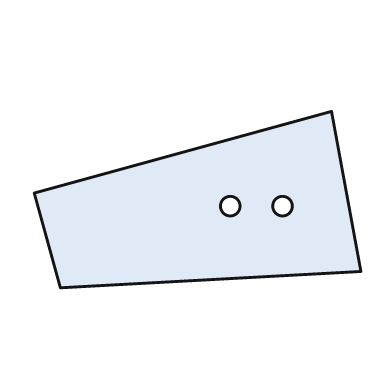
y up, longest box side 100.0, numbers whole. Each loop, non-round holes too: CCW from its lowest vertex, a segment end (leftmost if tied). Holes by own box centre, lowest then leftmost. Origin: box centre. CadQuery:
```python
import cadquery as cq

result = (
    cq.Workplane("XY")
    .moveTo(-42.0, -27.0)
    .lineTo(50.0, -22.0)
    .lineTo(41.0, 27.0)
    .lineTo(-50.0, 2.0)
    .close()
    .moveTo(10.0, -2.0)
    .circle(3.0)
    .moveTo(26.0, -2.0)
    .circle(3.0)
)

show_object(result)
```